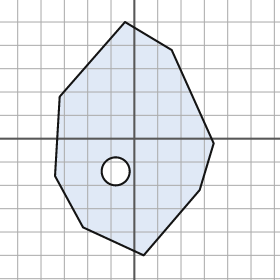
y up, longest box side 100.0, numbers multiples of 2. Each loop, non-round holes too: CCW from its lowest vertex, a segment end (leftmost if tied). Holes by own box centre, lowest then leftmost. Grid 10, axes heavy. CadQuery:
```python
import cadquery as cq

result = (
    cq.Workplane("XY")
    .moveTo(4.0, -50.0)
    .lineTo(28.0, -22.0)
    .lineTo(34.0, -2.0)
    .lineTo(16.0, 38.0)
    .lineTo(-4.0, 50.0)
    .lineTo(-32.0, 18.0)
    .lineTo(-34.0, -16.0)
    .lineTo(-22.0, -38.0)
    .close()
    .moveTo(-8.0, -14.0)
    .circle(6.0)
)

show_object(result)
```